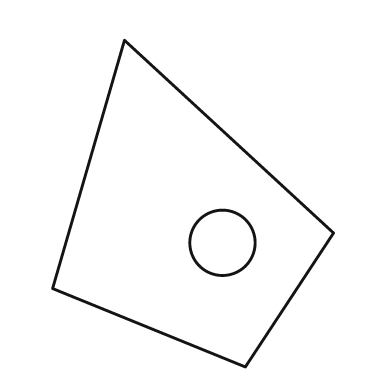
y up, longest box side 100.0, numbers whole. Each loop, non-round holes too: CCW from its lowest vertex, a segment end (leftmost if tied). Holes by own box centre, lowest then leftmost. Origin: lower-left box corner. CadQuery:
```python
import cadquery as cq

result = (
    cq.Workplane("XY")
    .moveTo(59.0, 0.0)
    .lineTo(86.0, 41.0)
    .lineTo(22.0, 100.0)
    .lineTo(0.0, 24.0)
    .close()
    .moveTo(52.0, 38.0)
    .circle(10.0)
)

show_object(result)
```